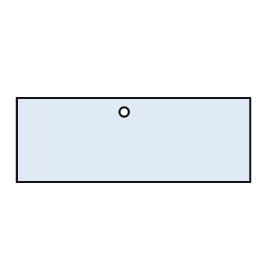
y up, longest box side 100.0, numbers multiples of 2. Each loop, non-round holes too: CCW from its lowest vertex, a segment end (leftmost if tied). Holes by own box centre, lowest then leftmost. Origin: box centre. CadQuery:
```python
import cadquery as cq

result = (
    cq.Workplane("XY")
    .moveTo(-50.0, -18.0)
    .lineTo(50.0, -18.0)
    .lineTo(50.0, 18.0)
    .lineTo(-50.0, 18.0)
    .close()
    .moveTo(-4.0, 12.0)
    .circle(2.0)
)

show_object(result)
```